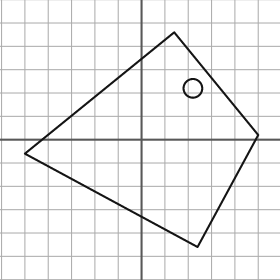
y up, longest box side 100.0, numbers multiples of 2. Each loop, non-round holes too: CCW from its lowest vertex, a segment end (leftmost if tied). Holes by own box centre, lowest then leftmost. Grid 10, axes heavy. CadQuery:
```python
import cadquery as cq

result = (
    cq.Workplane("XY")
    .moveTo(24.0, -46.0)
    .lineTo(50.0, 2.0)
    .lineTo(14.0, 46.0)
    .lineTo(-50.0, -6.0)
    .close()
    .moveTo(22.0, 22.0)
    .circle(4.0)
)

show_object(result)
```